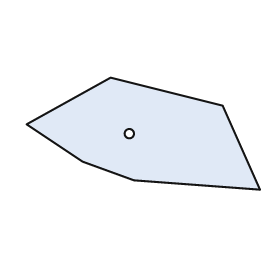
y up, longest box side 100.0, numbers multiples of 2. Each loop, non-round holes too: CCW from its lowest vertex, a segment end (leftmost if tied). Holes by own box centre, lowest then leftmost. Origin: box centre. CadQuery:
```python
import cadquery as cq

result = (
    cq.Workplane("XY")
    .moveTo(50.0, -24.0)
    .lineTo(34.0, 12.0)
    .lineTo(-14.0, 24.0)
    .lineTo(-50.0, 4.0)
    .lineTo(-26.0, -12.0)
    .lineTo(-4.0, -20.0)
    .close()
    .moveTo(-6.0, 0.0)
    .circle(2.0)
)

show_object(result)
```